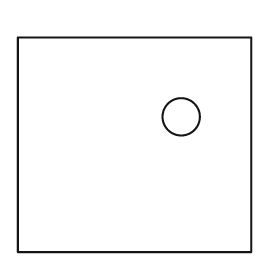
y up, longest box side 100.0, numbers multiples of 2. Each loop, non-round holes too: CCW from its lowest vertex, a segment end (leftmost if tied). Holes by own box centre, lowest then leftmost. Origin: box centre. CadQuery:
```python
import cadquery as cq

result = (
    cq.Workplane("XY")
    .moveTo(-50.0, -46.0)
    .lineTo(50.0, -46.0)
    .lineTo(50.0, 46.0)
    .lineTo(-50.0, 46.0)
    .close()
    .moveTo(20.0, 12.0)
    .circle(8.0)
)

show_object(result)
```